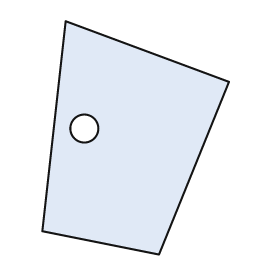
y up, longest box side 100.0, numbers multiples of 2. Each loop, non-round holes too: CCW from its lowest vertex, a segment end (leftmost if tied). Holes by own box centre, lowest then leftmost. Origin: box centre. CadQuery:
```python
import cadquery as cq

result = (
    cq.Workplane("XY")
    .moveTo(10.0, -50.0)
    .lineTo(40.0, 24.0)
    .lineTo(-30.0, 50.0)
    .lineTo(-40.0, -40.0)
    .close()
    .moveTo(-22.0, 4.0)
    .circle(6.0)
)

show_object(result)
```